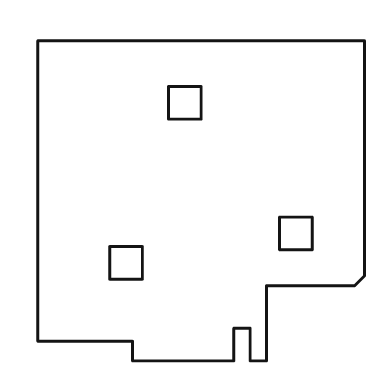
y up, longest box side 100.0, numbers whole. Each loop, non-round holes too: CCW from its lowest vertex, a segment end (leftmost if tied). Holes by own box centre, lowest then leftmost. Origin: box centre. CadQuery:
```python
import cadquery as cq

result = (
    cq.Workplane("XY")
    .moveTo(-21.0, -49.0)
    .lineTo(10.0, -49.0)
    .lineTo(10.0, -39.0)
    .lineTo(15.0, -39.0)
    .lineTo(15.0, -49.0)
    .lineTo(20.0, -49.0)
    .lineTo(20.0, -26.0)
    .lineTo(47.0, -26.0)
    .lineTo(50.0, -23.0)
    .lineTo(50.0, 49.0)
    .lineTo(-50.0, 49.0)
    .lineTo(-50.0, -43.0)
    .lineTo(-21.0, -43.0)
    .close()
    .moveTo(-28.0, -24.0)
    .lineTo(-18.0, -24.0)
    .lineTo(-18.0, -14.0)
    .lineTo(-28.0, -14.0)
    .close()
    .moveTo(24.0, -15.0)
    .lineTo(34.0, -15.0)
    .lineTo(34.0, -5.0)
    .lineTo(24.0, -5.0)
    .close()
    .moveTo(-10.0, 25.0)
    .lineTo(0.0, 25.0)
    .lineTo(0.0, 35.0)
    .lineTo(-10.0, 35.0)
    .close()
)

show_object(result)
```